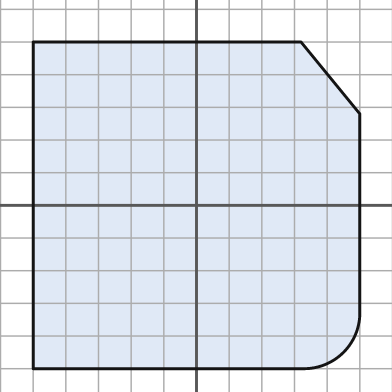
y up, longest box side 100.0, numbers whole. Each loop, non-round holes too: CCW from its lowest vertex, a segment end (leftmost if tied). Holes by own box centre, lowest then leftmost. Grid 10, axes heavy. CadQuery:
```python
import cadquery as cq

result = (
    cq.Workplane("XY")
    .moveTo(-50.0, -50.0)
    .lineTo(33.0, -50.0)
    .threePointArc((45.0, -45.0), (50.0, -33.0))
    .lineTo(50.0, 28.0)
    .lineTo(32.0, 50.0)
    .lineTo(-50.0, 50.0)
    .close()
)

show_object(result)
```